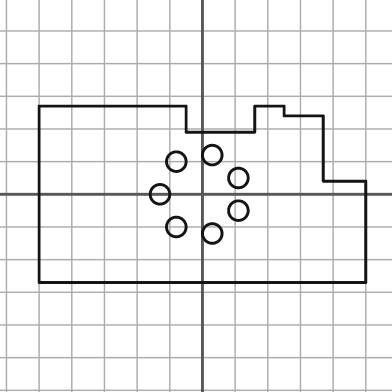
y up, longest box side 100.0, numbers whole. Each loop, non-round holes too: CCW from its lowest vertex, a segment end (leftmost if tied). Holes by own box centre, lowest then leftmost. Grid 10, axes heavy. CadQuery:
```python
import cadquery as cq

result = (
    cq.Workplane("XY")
    .moveTo(-50.0, -27.0)
    .lineTo(50.0, -27.0)
    .lineTo(50.0, 4.0)
    .lineTo(37.0, 4.0)
    .lineTo(37.0, 24.0)
    .lineTo(25.0, 24.0)
    .lineTo(25.0, 27.0)
    .lineTo(16.0, 27.0)
    .lineTo(16.0, 19.0)
    .lineTo(-5.0, 19.0)
    .lineTo(-5.0, 27.0)
    .lineTo(-50.0, 27.0)
    .close()
    .moveTo(3.0, -12.0)
    .circle(3.0)
    .moveTo(-8.0, -10.0)
    .circle(3.0)
    .moveTo(11.0, -5.0)
    .circle(3.0)
    .moveTo(-13.0, 0.0)
    .circle(3.0)
    .moveTo(11.0, 5.0)
    .circle(3.0)
    .moveTo(-8.0, 10.0)
    .circle(3.0)
    .moveTo(3.0, 12.0)
    .circle(3.0)
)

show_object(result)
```